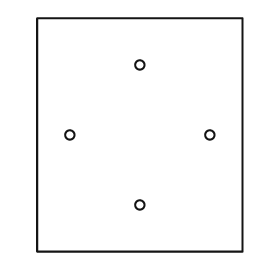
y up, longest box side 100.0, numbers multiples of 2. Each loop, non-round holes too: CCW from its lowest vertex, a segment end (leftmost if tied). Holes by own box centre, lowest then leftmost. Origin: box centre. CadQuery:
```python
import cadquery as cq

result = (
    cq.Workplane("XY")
    .moveTo(-44.0, -50.0)
    .lineTo(44.0, -50.0)
    .lineTo(44.0, 50.0)
    .lineTo(-44.0, 50.0)
    .close()
    .moveTo(0.0, -30.0)
    .circle(2.0)
    .moveTo(-30.0, 0.0)
    .circle(2.0)
    .moveTo(30.0, 0.0)
    .circle(2.0)
    .moveTo(0.0, 30.0)
    .circle(2.0)
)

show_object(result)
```